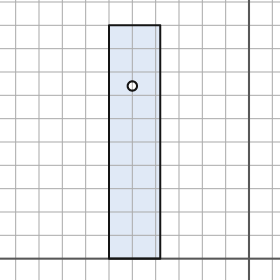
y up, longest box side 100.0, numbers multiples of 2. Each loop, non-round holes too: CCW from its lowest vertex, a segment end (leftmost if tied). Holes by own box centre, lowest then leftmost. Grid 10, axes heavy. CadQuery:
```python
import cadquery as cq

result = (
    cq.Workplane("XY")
    .moveTo(-60.0, 0.0)
    .lineTo(-38.0, 0.0)
    .lineTo(-38.0, 100.0)
    .lineTo(-60.0, 100.0)
    .close()
    .moveTo(-50.0, 74.0)
    .circle(2.0)
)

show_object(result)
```